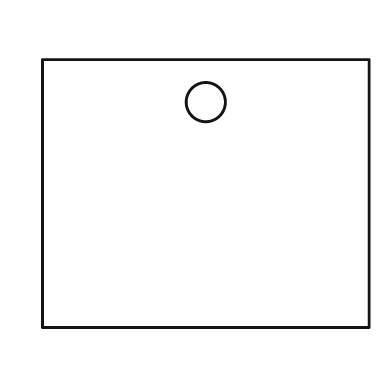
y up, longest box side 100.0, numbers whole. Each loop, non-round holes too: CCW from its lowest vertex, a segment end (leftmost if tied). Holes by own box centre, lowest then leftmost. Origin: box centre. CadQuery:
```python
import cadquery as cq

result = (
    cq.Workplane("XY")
    .moveTo(-50.0, -41.0)
    .lineTo(50.0, -41.0)
    .lineTo(50.0, 41.0)
    .lineTo(-50.0, 41.0)
    .close()
    .moveTo(0.0, 28.0)
    .circle(6.0)
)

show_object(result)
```